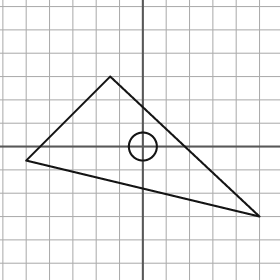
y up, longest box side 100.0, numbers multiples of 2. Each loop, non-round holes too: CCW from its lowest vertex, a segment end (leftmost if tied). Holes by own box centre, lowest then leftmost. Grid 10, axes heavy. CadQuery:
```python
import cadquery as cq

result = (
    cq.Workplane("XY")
    .moveTo(50.0, -30.0)
    .lineTo(-14.0, 30.0)
    .lineTo(-50.0, -6.0)
    .close()
    .moveTo(0.0, 0.0)
    .circle(6.0)
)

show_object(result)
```